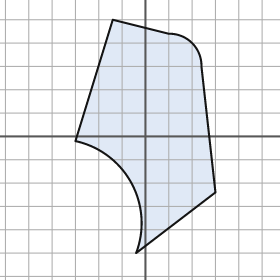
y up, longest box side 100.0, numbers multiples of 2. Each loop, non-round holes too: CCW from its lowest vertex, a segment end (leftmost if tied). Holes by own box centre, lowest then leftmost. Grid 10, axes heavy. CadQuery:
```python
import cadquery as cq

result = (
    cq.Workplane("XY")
    .moveTo(-4.0, -50.0)
    .lineTo(30.0, -24.0)
    .lineTo(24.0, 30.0)
    .threePointArc((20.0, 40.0), (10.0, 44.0))
    .lineTo(-14.0, 50.0)
    .lineTo(-30.0, -2.0)
    .threePointArc((-6.0, -20.0), (-4.0, -50.0))
    .close()
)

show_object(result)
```